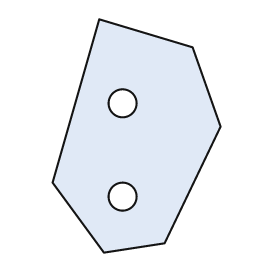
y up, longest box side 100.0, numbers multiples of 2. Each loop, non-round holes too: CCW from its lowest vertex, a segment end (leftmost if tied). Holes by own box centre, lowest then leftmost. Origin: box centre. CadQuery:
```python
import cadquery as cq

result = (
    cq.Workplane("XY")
    .moveTo(-14.0, -50.0)
    .lineTo(12.0, -46.0)
    .lineTo(36.0, 4.0)
    .lineTo(24.0, 38.0)
    .lineTo(-16.0, 50.0)
    .lineTo(-36.0, -20.0)
    .close()
    .moveTo(-6.0, -26.0)
    .circle(6.0)
    .moveTo(-6.0, 14.0)
    .circle(6.0)
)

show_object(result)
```